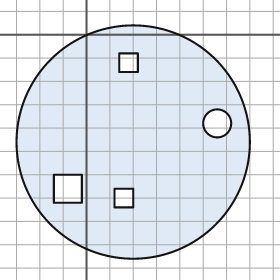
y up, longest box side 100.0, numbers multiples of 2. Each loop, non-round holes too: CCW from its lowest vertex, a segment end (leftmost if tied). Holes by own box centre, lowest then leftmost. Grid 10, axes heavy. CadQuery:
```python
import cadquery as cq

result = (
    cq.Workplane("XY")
    .moveTo(20.0, -46.0)
    .circle(50.0)
    .moveTo(12.0, -74.0)
    .lineTo(20.0, -74.0)
    .lineTo(20.0, -66.0)
    .lineTo(12.0, -66.0)
    .close()
    .moveTo(-14.0, -72.0)
    .lineTo(-2.0, -72.0)
    .lineTo(-2.0, -60.0)
    .lineTo(-14.0, -60.0)
    .close()
    .moveTo(56.0, -38.0)
    .circle(6.0)
    .moveTo(14.0, -16.0)
    .lineTo(22.0, -16.0)
    .lineTo(22.0, -8.0)
    .lineTo(14.0, -8.0)
    .close()
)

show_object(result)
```